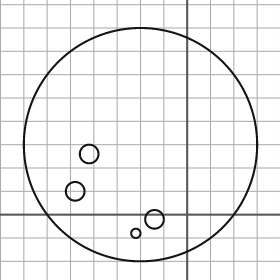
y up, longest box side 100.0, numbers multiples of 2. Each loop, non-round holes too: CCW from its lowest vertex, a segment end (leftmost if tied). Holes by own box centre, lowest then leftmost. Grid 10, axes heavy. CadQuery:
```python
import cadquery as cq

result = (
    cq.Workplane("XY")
    .moveTo(-20.0, 30.0)
    .circle(50.0)
    .moveTo(-22.0, -8.0)
    .circle(2.0)
    .moveTo(-14.0, -2.0)
    .circle(4.0)
    .moveTo(-48.0, 10.0)
    .circle(4.0)
    .moveTo(-42.0, 26.0)
    .circle(4.0)
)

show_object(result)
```